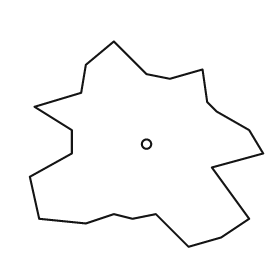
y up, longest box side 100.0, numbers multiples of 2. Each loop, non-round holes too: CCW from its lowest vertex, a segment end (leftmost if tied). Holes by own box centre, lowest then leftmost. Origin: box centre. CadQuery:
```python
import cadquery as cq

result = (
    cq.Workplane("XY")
    .moveTo(18.0, -44.0)
    .lineTo(32.0, -40.0)
    .lineTo(44.0, -32.0)
    .lineTo(28.0, -10.0)
    .lineTo(50.0, -4.0)
    .lineTo(44.0, 6.0)
    .lineTo(30.0, 14.0)
    .lineTo(26.0, 18.0)
    .lineTo(24.0, 32.0)
    .lineTo(10.0, 28.0)
    .lineTo(0.0, 30.0)
    .lineTo(-14.0, 44.0)
    .lineTo(-26.0, 34.0)
    .lineTo(-28.0, 22.0)
    .lineTo(-48.0, 16.0)
    .lineTo(-32.0, 6.0)
    .lineTo(-32.0, -4.0)
    .lineTo(-50.0, -14.0)
    .lineTo(-46.0, -32.0)
    .lineTo(-26.0, -34.0)
    .lineTo(-14.0, -30.0)
    .lineTo(-6.0, -32.0)
    .lineTo(4.0, -30.0)
    .close()
    .moveTo(0.0, 0.0)
    .circle(2.0)
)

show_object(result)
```